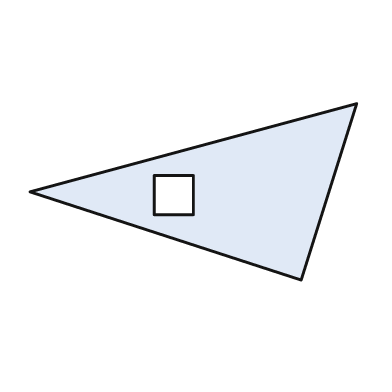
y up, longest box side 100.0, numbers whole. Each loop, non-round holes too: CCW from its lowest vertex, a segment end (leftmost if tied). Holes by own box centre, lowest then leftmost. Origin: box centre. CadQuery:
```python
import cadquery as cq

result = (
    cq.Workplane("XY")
    .moveTo(33.0, -27.0)
    .lineTo(50.0, 27.0)
    .lineTo(-50.0, 0.0)
    .close()
    .moveTo(-12.0, -7.0)
    .lineTo(0.0, -7.0)
    .lineTo(0.0, 5.0)
    .lineTo(-12.0, 5.0)
    .close()
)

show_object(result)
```